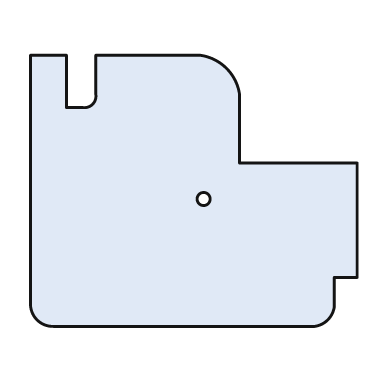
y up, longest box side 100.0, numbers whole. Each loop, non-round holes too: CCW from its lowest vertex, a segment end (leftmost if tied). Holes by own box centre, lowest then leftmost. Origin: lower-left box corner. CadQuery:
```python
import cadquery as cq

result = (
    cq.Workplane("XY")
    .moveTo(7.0, 0.0)
    .lineTo(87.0, 0.0)
    .threePointArc((91.0, 2.0), (93.0, 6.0))
    .lineTo(93.0, 15.0)
    .lineTo(100.0, 15.0)
    .lineTo(100.0, 50.0)
    .lineTo(64.0, 50.0)
    .lineTo(64.0, 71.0)
    .threePointArc((60.0, 79.0), (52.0, 83.0))
    .lineTo(20.0, 83.0)
    .lineTo(20.0, 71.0)
    .threePointArc((19.0, 68.0), (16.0, 67.0))
    .lineTo(11.0, 67.0)
    .lineTo(11.0, 83.0)
    .lineTo(0.0, 83.0)
    .lineTo(0.0, 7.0)
    .threePointArc((2.0, 2.0), (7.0, 0.0))
    .close()
    .moveTo(53.0, 39.0)
    .circle(2.0)
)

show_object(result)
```